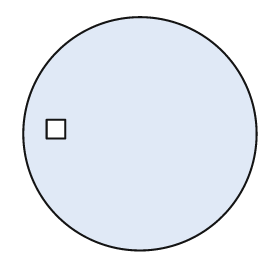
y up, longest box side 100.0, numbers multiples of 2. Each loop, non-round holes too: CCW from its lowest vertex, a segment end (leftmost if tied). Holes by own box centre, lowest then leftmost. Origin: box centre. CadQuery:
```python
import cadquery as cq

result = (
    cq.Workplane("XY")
    .moveTo(0.0, 0.0)
    .circle(50.0)
    .moveTo(-40.0, -2.0)
    .lineTo(-32.0, -2.0)
    .lineTo(-32.0, 6.0)
    .lineTo(-40.0, 6.0)
    .close()
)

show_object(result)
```